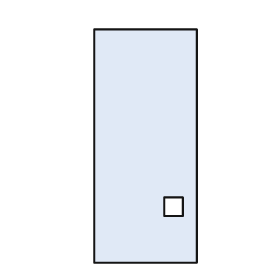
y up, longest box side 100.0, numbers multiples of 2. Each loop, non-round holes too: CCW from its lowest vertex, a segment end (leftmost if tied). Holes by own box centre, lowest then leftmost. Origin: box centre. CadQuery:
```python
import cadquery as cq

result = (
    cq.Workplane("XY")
    .moveTo(-22.0, -50.0)
    .lineTo(22.0, -50.0)
    .lineTo(22.0, 50.0)
    .lineTo(-22.0, 50.0)
    .close()
    .moveTo(8.0, -30.0)
    .lineTo(16.0, -30.0)
    .lineTo(16.0, -22.0)
    .lineTo(8.0, -22.0)
    .close()
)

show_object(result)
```